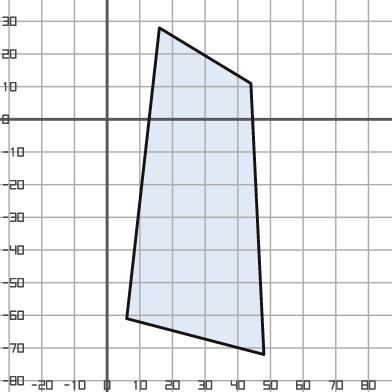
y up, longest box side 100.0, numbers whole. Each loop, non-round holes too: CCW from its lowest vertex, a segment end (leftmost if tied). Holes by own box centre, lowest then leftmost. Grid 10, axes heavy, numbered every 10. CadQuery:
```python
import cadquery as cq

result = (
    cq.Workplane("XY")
    .moveTo(48.0, -72.0)
    .lineTo(44.0, 11.0)
    .lineTo(16.0, 28.0)
    .lineTo(6.0, -61.0)
    .close()
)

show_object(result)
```